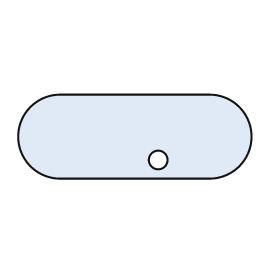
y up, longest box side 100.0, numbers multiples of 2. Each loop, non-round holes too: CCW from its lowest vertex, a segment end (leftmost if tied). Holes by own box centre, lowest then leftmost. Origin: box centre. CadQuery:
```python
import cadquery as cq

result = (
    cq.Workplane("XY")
    .moveTo(-32.0, -18.0)
    .lineTo(32.0, -18.0)
    .threePointArc((50.0, 0.0), (32.0, 18.0))
    .lineTo(-32.0, 18.0)
    .threePointArc((-50.0, 0.0), (-32.0, -18.0))
    .close()
    .moveTo(10.0, -10.0)
    .circle(4.0)
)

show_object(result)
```